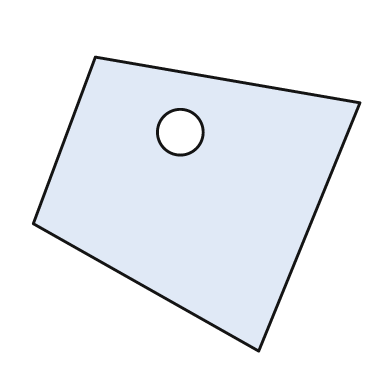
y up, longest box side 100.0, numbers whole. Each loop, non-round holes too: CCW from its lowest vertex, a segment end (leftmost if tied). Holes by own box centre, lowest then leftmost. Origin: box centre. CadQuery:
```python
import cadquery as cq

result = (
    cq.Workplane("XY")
    .moveTo(19.0, -45.0)
    .lineTo(50.0, 31.0)
    .lineTo(-31.0, 45.0)
    .lineTo(-50.0, -6.0)
    .close()
    .moveTo(-5.0, 22.0)
    .circle(7.0)
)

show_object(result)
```